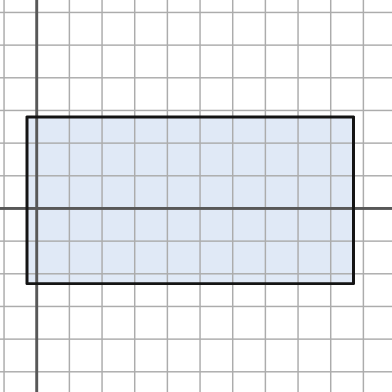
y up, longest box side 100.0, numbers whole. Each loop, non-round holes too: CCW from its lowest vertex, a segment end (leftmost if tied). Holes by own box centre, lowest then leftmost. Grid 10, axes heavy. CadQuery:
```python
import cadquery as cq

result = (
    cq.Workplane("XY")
    .moveTo(-3.0, -23.0)
    .lineTo(97.0, -23.0)
    .lineTo(97.0, 28.0)
    .lineTo(-3.0, 28.0)
    .close()
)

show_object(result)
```